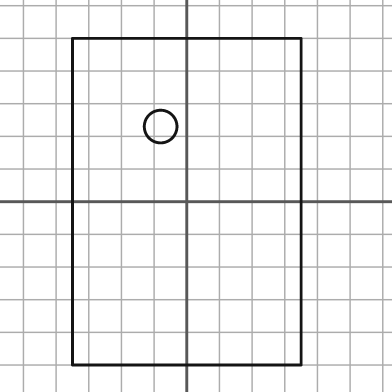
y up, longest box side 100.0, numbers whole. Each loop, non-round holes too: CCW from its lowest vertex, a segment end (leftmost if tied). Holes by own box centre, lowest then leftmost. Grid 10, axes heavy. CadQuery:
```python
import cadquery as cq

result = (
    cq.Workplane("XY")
    .moveTo(-35.0, -50.0)
    .lineTo(35.0, -50.0)
    .lineTo(35.0, 50.0)
    .lineTo(-35.0, 50.0)
    .close()
    .moveTo(-8.0, 23.0)
    .circle(5.0)
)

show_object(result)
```